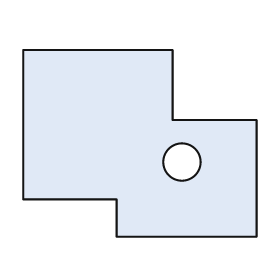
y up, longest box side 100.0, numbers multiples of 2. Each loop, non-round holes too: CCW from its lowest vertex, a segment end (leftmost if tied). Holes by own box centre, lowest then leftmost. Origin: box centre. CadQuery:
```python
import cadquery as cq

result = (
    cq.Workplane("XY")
    .moveTo(-10.0, -40.0)
    .lineTo(50.0, -40.0)
    .lineTo(50.0, 10.0)
    .lineTo(14.0, 10.0)
    .lineTo(14.0, 40.0)
    .lineTo(-50.0, 40.0)
    .lineTo(-50.0, -24.0)
    .lineTo(-10.0, -24.0)
    .close()
    .moveTo(18.0, -8.0)
    .circle(8.0)
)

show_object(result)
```